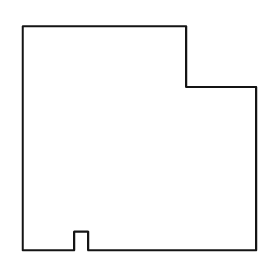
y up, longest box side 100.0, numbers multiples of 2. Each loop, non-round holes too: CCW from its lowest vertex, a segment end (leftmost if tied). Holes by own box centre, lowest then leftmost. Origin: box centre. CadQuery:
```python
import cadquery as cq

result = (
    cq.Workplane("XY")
    .moveTo(-50.0, -48.0)
    .lineTo(-28.0, -48.0)
    .lineTo(-28.0, -40.0)
    .lineTo(-22.0, -40.0)
    .lineTo(-22.0, -48.0)
    .lineTo(50.0, -48.0)
    .lineTo(50.0, 22.0)
    .lineTo(20.0, 22.0)
    .lineTo(20.0, 48.0)
    .lineTo(-50.0, 48.0)
    .close()
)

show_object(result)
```